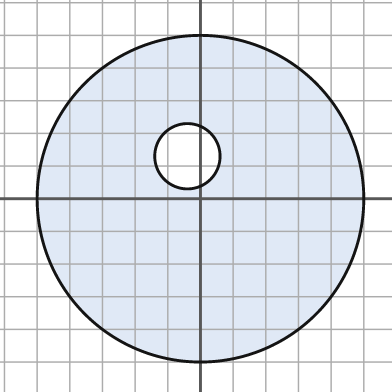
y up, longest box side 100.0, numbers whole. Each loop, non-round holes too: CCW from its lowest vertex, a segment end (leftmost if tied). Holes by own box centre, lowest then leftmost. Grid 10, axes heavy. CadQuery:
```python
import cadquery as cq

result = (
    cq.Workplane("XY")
    .moveTo(0.0, 0.0)
    .circle(50.0)
    .moveTo(-4.0, 13.0)
    .circle(10.0)
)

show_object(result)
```